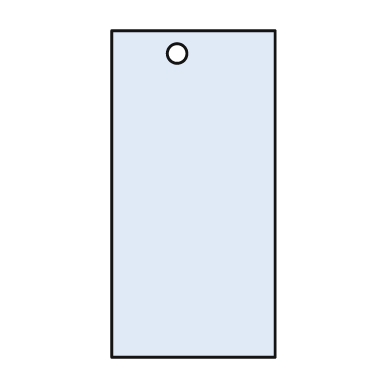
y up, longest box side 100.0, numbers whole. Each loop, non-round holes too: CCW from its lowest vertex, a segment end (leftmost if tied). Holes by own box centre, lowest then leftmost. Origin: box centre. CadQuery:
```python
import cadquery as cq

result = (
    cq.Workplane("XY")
    .moveTo(-25.0, -50.0)
    .lineTo(25.0, -50.0)
    .lineTo(25.0, 50.0)
    .lineTo(-25.0, 50.0)
    .close()
    .moveTo(-5.0, 43.0)
    .circle(3.0)
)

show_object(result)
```